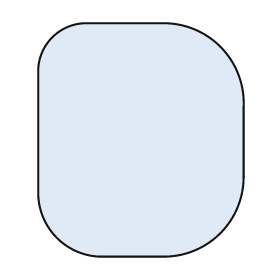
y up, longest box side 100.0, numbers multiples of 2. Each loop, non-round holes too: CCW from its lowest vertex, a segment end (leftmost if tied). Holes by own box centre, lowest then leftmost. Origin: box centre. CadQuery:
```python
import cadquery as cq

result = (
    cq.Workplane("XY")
    .moveTo(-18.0, -50.0)
    .lineTo(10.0, -50.0)
    .threePointArc((34.0, -40.0), (44.0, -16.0))
    .lineTo(44.0, 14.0)
    .threePointArc((34.0, 40.0), (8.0, 50.0))
    .lineTo(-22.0, 50.0)
    .threePointArc((-38.0, 44.0), (-44.0, 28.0))
    .lineTo(-44.0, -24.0)
    .threePointArc((-36.0, -42.0), (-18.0, -50.0))
    .close()
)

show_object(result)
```